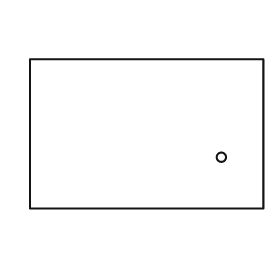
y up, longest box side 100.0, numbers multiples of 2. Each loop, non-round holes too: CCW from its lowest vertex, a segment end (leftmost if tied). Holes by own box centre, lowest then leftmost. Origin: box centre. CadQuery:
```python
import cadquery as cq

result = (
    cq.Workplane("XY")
    .moveTo(-50.0, -32.0)
    .lineTo(50.0, -32.0)
    .lineTo(50.0, 32.0)
    .lineTo(-50.0, 32.0)
    .close()
    .moveTo(32.0, -10.0)
    .circle(2.0)
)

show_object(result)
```